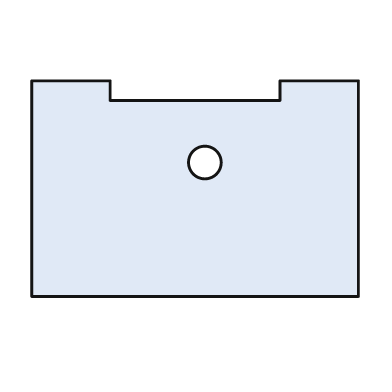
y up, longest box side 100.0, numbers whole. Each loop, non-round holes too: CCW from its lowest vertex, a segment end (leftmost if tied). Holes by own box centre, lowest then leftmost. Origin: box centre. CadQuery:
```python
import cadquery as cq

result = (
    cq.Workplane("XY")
    .moveTo(-50.0, -33.0)
    .lineTo(50.0, -33.0)
    .lineTo(50.0, 33.0)
    .lineTo(26.0, 33.0)
    .lineTo(26.0, 27.0)
    .lineTo(-26.0, 27.0)
    .lineTo(-26.0, 33.0)
    .lineTo(-50.0, 33.0)
    .close()
    .moveTo(3.0, 8.0)
    .circle(5.0)
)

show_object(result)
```